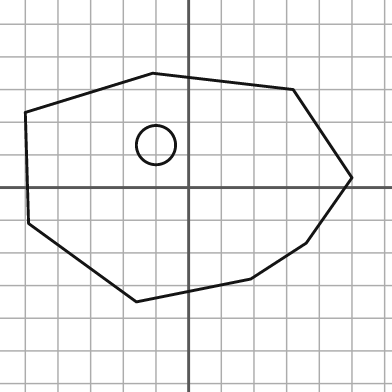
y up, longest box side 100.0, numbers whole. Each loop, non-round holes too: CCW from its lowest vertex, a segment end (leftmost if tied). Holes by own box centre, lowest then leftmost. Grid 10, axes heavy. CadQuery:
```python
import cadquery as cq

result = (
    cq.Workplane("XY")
    .moveTo(-16.0, -35.0)
    .lineTo(19.0, -28.0)
    .lineTo(36.0, -17.0)
    .lineTo(50.0, 3.0)
    .lineTo(32.0, 30.0)
    .lineTo(-11.0, 35.0)
    .lineTo(-50.0, 23.0)
    .lineTo(-49.0, -11.0)
    .close()
    .moveTo(-10.0, 13.0)
    .circle(6.0)
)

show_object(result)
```